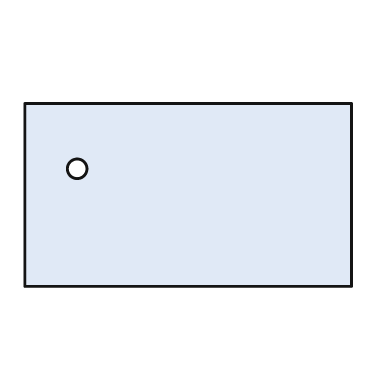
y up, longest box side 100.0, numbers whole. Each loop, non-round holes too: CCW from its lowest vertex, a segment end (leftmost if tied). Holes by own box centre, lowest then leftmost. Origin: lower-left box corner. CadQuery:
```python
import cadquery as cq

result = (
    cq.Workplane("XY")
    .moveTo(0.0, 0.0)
    .lineTo(100.0, 0.0)
    .lineTo(100.0, 56.0)
    .lineTo(0.0, 56.0)
    .close()
    .moveTo(16.0, 36.0)
    .circle(3.0)
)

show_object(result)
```